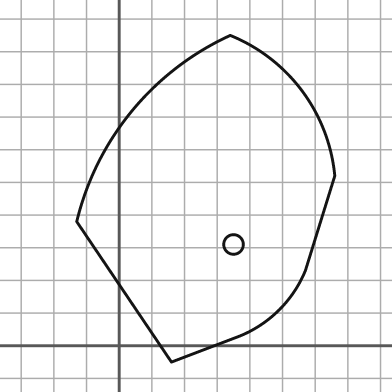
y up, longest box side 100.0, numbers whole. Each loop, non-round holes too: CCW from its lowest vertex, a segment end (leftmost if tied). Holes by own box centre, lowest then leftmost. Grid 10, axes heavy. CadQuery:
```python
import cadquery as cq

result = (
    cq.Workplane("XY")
    .moveTo(16.0, -5.0)
    .lineTo(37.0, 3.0)
    .threePointArc((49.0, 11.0), (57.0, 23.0))
    .lineTo(66.0, 52.0)
    .threePointArc((56.0, 78.0), (34.0, 95.0))
    .threePointArc((4.0, 72.0), (-13.0, 38.0))
    .close()
    .moveTo(35.0, 31.0)
    .circle(3.0)
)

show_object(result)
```